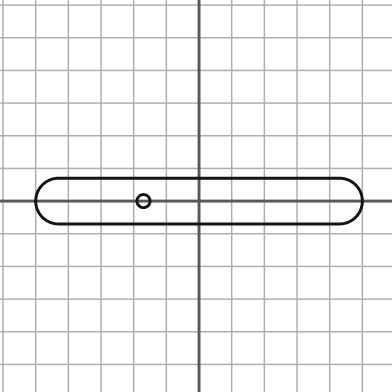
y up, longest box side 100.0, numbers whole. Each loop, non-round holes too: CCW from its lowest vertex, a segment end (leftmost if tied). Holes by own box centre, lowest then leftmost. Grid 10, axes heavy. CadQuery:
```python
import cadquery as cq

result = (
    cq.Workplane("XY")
    .moveTo(-43.0, -7.0)
    .lineTo(43.0, -7.0)
    .threePointArc((50.0, 0.0), (43.0, 7.0))
    .lineTo(-43.0, 7.0)
    .threePointArc((-50.0, 0.0), (-43.0, -7.0))
    .close()
    .moveTo(-17.0, 0.0)
    .circle(2.0)
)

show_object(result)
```